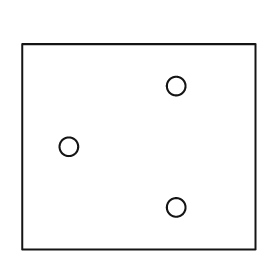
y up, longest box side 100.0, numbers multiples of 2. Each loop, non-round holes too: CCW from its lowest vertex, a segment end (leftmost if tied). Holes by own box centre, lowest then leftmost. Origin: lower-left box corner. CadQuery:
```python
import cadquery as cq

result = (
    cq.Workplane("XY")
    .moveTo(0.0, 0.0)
    .lineTo(100.0, 0.0)
    .lineTo(100.0, 88.0)
    .lineTo(0.0, 88.0)
    .close()
    .moveTo(66.0, 18.0)
    .circle(4.0)
    .moveTo(20.0, 44.0)
    .circle(4.0)
    .moveTo(66.0, 70.0)
    .circle(4.0)
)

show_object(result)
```